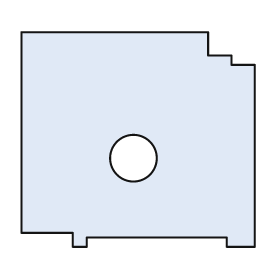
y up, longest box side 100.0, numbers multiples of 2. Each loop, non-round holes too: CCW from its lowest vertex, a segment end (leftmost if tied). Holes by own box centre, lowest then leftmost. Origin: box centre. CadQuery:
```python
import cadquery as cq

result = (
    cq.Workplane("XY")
    .moveTo(-28.0, -46.0)
    .lineTo(-22.0, -46.0)
    .lineTo(-22.0, -42.0)
    .lineTo(38.0, -42.0)
    .lineTo(38.0, -46.0)
    .lineTo(50.0, -46.0)
    .lineTo(50.0, 32.0)
    .lineTo(40.0, 32.0)
    .lineTo(40.0, 36.0)
    .lineTo(30.0, 36.0)
    .lineTo(30.0, 46.0)
    .lineTo(-50.0, 46.0)
    .lineTo(-50.0, -40.0)
    .lineTo(-28.0, -40.0)
    .close()
    .moveTo(-2.0, -8.0)
    .circle(10.0)
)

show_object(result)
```